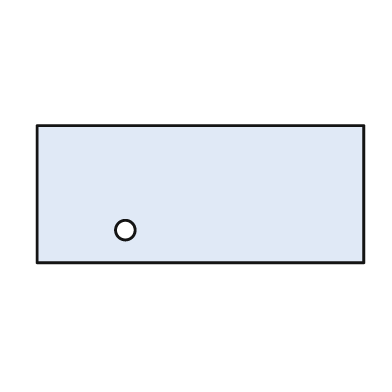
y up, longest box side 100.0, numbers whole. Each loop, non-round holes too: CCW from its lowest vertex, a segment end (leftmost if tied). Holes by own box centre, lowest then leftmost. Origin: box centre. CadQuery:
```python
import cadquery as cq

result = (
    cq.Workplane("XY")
    .moveTo(-50.0, -21.0)
    .lineTo(50.0, -21.0)
    .lineTo(50.0, 21.0)
    .lineTo(-50.0, 21.0)
    .close()
    .moveTo(-23.0, -11.0)
    .circle(3.0)
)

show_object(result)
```